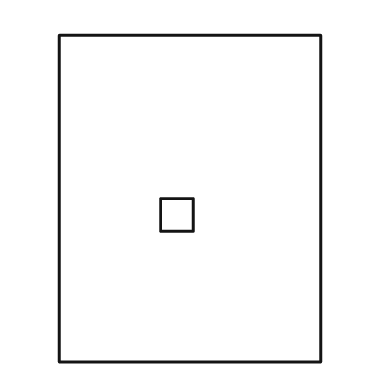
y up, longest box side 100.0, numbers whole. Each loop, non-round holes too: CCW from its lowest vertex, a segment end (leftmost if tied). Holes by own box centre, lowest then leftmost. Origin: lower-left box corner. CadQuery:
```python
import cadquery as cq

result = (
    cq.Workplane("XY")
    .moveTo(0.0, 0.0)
    .lineTo(80.0, 0.0)
    .lineTo(80.0, 100.0)
    .lineTo(0.0, 100.0)
    .close()
    .moveTo(31.0, 40.0)
    .lineTo(41.0, 40.0)
    .lineTo(41.0, 50.0)
    .lineTo(31.0, 50.0)
    .close()
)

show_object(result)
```